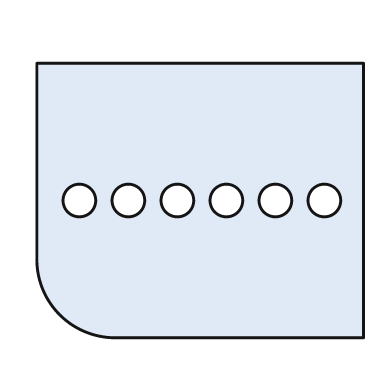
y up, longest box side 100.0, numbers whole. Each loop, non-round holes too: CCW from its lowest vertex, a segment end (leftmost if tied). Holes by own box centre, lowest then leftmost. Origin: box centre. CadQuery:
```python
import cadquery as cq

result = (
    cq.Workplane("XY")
    .moveTo(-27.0, -42.0)
    .lineTo(50.0, -42.0)
    .lineTo(50.0, 42.0)
    .lineTo(-50.0, 42.0)
    .lineTo(-50.0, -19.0)
    .threePointArc((-43.0, -35.0), (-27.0, -42.0))
    .close()
    .moveTo(-37.0, 0.0)
    .circle(5.0)
    .moveTo(-22.0, 0.0)
    .circle(5.0)
    .moveTo(-7.0, 0.0)
    .circle(5.0)
    .moveTo(8.0, 0.0)
    .circle(5.0)
    .moveTo(23.0, 0.0)
    .circle(5.0)
    .moveTo(38.0, 0.0)
    .circle(5.0)
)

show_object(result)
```